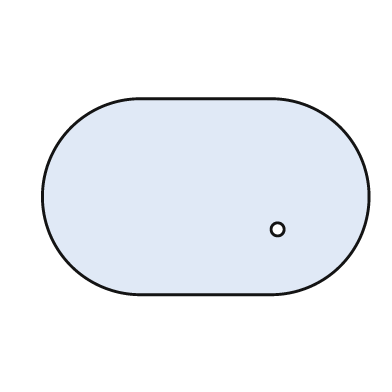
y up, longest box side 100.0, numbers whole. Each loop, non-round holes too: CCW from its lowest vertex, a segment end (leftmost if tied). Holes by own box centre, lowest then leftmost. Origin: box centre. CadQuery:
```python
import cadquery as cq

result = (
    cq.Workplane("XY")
    .moveTo(-20.0, -30.0)
    .lineTo(20.0, -30.0)
    .threePointArc((50.0, 0.0), (20.0, 30.0))
    .lineTo(-20.0, 30.0)
    .threePointArc((-50.0, 0.0), (-20.0, -30.0))
    .close()
    .moveTo(22.0, -10.0)
    .circle(2.0)
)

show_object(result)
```